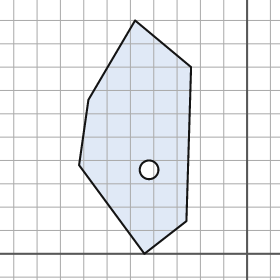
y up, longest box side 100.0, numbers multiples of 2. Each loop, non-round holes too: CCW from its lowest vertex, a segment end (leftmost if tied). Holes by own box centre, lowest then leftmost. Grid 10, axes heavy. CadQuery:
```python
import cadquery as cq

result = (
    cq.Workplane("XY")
    .moveTo(-44.0, 0.0)
    .lineTo(-26.0, 14.0)
    .lineTo(-24.0, 80.0)
    .lineTo(-48.0, 100.0)
    .lineTo(-68.0, 66.0)
    .lineTo(-72.0, 38.0)
    .close()
    .moveTo(-42.0, 36.0)
    .circle(4.0)
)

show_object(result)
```